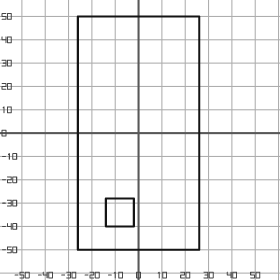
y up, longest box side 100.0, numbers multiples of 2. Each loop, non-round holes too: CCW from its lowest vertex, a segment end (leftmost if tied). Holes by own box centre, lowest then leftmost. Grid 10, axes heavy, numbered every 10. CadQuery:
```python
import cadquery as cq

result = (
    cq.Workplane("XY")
    .moveTo(-26.0, -50.0)
    .lineTo(26.0, -50.0)
    .lineTo(26.0, 50.0)
    .lineTo(-26.0, 50.0)
    .close()
    .moveTo(-14.0, -40.0)
    .lineTo(-2.0, -40.0)
    .lineTo(-2.0, -28.0)
    .lineTo(-14.0, -28.0)
    .close()
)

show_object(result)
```